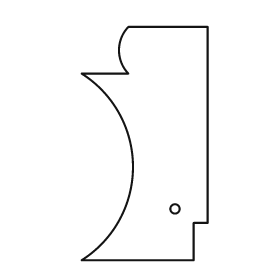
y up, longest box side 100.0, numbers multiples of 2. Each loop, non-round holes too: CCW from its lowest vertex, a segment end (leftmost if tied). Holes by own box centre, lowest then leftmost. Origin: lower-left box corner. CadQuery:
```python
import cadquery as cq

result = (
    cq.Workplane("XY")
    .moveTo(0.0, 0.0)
    .lineTo(48.0, 0.0)
    .lineTo(48.0, 16.0)
    .lineTo(54.0, 16.0)
    .lineTo(54.0, 100.0)
    .lineTo(20.0, 100.0)
    .threePointArc((16.0, 90.0), (20.0, 80.0))
    .lineTo(0.0, 80.0)
    .threePointArc((22.0, 40.0), (0.0, 0.0))
    .close()
    .moveTo(40.0, 22.0)
    .circle(2.0)
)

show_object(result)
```